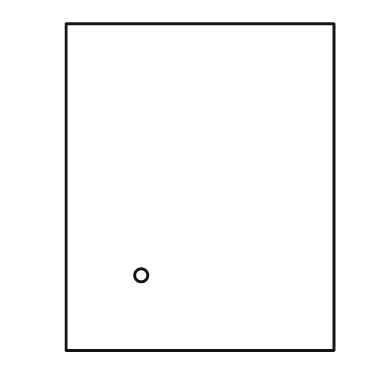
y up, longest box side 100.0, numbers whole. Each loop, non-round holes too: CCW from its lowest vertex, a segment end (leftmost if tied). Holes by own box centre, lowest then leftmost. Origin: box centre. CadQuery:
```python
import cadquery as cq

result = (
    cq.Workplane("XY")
    .moveTo(-41.0, -50.0)
    .lineTo(41.0, -50.0)
    .lineTo(41.0, 50.0)
    .lineTo(-41.0, 50.0)
    .close()
    .moveTo(-18.0, -27.0)
    .circle(2.0)
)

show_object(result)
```